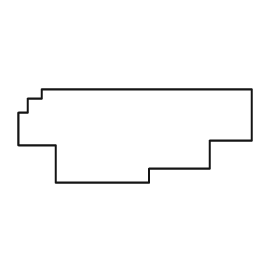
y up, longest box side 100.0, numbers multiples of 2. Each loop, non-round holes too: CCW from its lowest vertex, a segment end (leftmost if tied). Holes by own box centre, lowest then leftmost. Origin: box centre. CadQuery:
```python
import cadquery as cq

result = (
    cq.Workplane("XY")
    .moveTo(-34.0, -20.0)
    .lineTo(6.0, -20.0)
    .lineTo(6.0, -14.0)
    .lineTo(32.0, -14.0)
    .lineTo(32.0, -2.0)
    .lineTo(50.0, -2.0)
    .lineTo(50.0, 20.0)
    .lineTo(-40.0, 20.0)
    .lineTo(-40.0, 16.0)
    .lineTo(-46.0, 16.0)
    .lineTo(-46.0, 10.0)
    .lineTo(-50.0, 10.0)
    .lineTo(-50.0, -4.0)
    .lineTo(-34.0, -4.0)
    .close()
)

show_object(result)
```